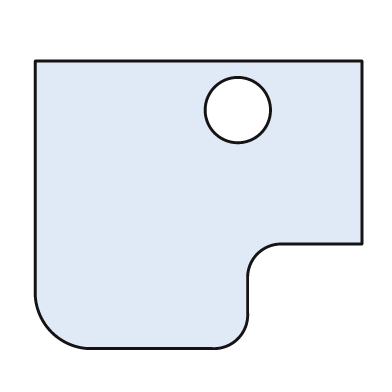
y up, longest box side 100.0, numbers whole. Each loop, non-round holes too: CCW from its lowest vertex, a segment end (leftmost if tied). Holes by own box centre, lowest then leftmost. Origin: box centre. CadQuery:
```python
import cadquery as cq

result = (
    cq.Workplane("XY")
    .moveTo(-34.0, -44.0)
    .lineTo(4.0, -44.0)
    .threePointArc((12.0, -41.0), (15.0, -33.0))
    .lineTo(15.0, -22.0)
    .threePointArc((18.0, -15.0), (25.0, -12.0))
    .lineTo(50.0, -12.0)
    .lineTo(50.0, 44.0)
    .lineTo(-50.0, 44.0)
    .lineTo(-50.0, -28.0)
    .threePointArc((-45.0, -39.0), (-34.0, -44.0))
    .close()
    .moveTo(12.0, 29.0)
    .circle(10.0)
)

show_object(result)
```